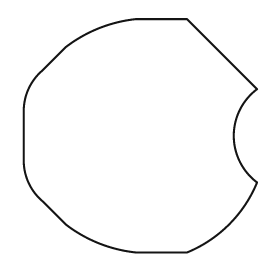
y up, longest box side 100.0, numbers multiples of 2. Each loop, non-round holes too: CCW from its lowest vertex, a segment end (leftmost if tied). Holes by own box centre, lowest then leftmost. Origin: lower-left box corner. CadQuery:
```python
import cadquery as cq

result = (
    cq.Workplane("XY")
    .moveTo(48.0, 0.0)
    .lineTo(70.0, 0.0)
    .threePointArc((88.0, 12.0), (100.0, 30.0))
    .threePointArc((90.0, 50.0), (100.0, 70.0))
    .lineTo(70.0, 100.0)
    .lineTo(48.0, 100.0)
    .threePointArc((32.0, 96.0), (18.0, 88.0))
    .lineTo(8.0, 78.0)
    .threePointArc((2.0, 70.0), (0.0, 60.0))
    .lineTo(0.0, 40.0)
    .threePointArc((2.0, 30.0), (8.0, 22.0))
    .lineTo(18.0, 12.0)
    .threePointArc((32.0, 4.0), (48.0, 0.0))
    .close()
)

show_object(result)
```